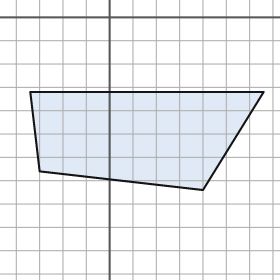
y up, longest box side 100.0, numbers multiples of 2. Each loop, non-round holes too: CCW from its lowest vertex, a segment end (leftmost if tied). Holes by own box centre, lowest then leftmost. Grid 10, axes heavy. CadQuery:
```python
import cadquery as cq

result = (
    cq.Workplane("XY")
    .moveTo(40.0, -74.0)
    .lineTo(66.0, -32.0)
    .lineTo(-34.0, -32.0)
    .lineTo(-30.0, -66.0)
    .close()
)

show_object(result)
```